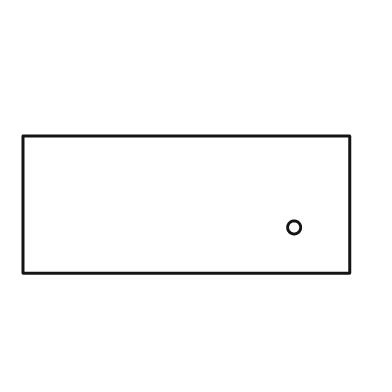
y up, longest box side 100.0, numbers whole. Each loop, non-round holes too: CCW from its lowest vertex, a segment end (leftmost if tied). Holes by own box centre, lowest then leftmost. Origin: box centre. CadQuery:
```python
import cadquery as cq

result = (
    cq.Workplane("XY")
    .moveTo(-50.0, -21.0)
    .lineTo(50.0, -21.0)
    .lineTo(50.0, 21.0)
    .lineTo(-50.0, 21.0)
    .close()
    .moveTo(33.0, -7.0)
    .circle(2.0)
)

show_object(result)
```